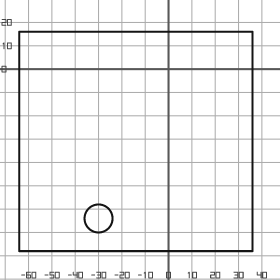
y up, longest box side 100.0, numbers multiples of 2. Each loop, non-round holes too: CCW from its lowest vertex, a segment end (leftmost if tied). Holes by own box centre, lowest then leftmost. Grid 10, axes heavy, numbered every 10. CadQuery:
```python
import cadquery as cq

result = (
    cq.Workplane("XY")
    .moveTo(-64.0, -78.0)
    .lineTo(36.0, -78.0)
    .lineTo(36.0, 16.0)
    .lineTo(-64.0, 16.0)
    .close()
    .moveTo(-30.0, -64.0)
    .circle(6.0)
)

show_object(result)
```